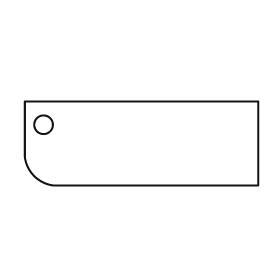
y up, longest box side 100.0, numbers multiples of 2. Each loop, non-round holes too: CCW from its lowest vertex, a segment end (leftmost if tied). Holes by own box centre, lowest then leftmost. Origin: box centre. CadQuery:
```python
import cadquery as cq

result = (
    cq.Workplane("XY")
    .moveTo(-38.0, -18.0)
    .lineTo(50.0, -18.0)
    .lineTo(50.0, 18.0)
    .lineTo(-50.0, 18.0)
    .lineTo(-50.0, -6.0)
    .threePointArc((-46.0, -14.0), (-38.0, -18.0))
    .close()
    .moveTo(-42.0, 8.0)
    .circle(4.0)
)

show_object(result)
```